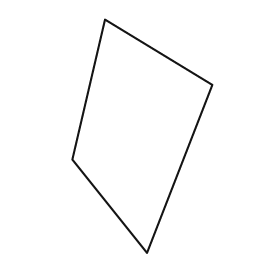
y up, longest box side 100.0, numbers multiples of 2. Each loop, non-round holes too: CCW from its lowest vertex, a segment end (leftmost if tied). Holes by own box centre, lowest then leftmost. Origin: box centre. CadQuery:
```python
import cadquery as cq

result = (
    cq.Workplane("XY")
    .moveTo(2.0, -50.0)
    .lineTo(30.0, 22.0)
    .lineTo(-16.0, 50.0)
    .lineTo(-30.0, -10.0)
    .close()
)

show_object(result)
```